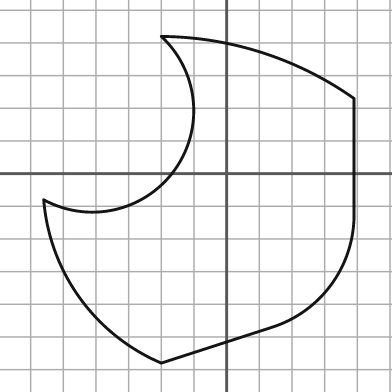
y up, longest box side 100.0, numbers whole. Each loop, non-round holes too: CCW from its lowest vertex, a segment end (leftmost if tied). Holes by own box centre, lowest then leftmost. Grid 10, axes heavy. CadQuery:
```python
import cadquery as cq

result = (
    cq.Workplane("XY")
    .moveTo(-20.0, -58.0)
    .lineTo(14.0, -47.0)
    .threePointArc((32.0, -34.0), (39.0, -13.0))
    .lineTo(39.0, 23.0)
    .threePointArc((11.0, 37.0), (-20.0, 42.0))
    .threePointArc((-16.0, 1.0), (-56.0, -8.0))
    .threePointArc((-45.0, -38.0), (-20.0, -58.0))
    .close()
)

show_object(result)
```